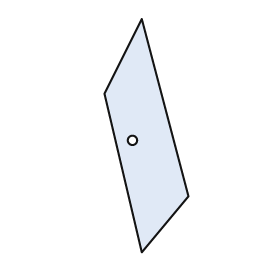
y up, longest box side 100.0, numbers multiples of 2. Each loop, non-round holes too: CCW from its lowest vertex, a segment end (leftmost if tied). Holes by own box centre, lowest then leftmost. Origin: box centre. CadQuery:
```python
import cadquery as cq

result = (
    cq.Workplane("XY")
    .moveTo(-2.0, -50.0)
    .lineTo(18.0, -26.0)
    .lineTo(-2.0, 50.0)
    .lineTo(-18.0, 18.0)
    .close()
    .moveTo(-6.0, -2.0)
    .circle(2.0)
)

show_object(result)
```